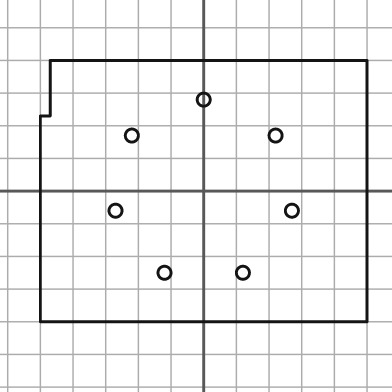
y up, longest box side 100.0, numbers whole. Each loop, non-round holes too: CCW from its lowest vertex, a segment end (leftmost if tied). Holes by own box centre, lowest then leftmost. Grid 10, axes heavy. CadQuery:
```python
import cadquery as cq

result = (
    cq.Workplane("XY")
    .moveTo(-50.0, -40.0)
    .lineTo(50.0, -40.0)
    .lineTo(50.0, 40.0)
    .lineTo(-47.0, 40.0)
    .lineTo(-47.0, 23.0)
    .lineTo(-50.0, 23.0)
    .close()
    .moveTo(-12.0, -25.0)
    .circle(2.0)
    .moveTo(12.0, -25.0)
    .circle(2.0)
    .moveTo(-27.0, -6.0)
    .circle(2.0)
    .moveTo(27.0, -6.0)
    .circle(2.0)
    .moveTo(-22.0, 17.0)
    .circle(2.0)
    .moveTo(22.0, 17.0)
    .circle(2.0)
    .moveTo(0.0, 28.0)
    .circle(2.0)
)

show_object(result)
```